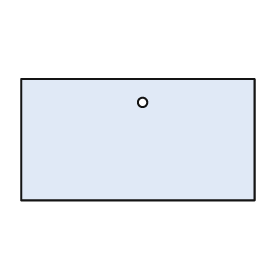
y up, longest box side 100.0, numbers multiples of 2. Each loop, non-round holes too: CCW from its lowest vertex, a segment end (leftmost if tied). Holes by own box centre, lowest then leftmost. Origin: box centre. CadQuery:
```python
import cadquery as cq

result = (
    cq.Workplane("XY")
    .moveTo(-50.0, -26.0)
    .lineTo(50.0, -26.0)
    .lineTo(50.0, 26.0)
    .lineTo(-50.0, 26.0)
    .close()
    .moveTo(2.0, 16.0)
    .circle(2.0)
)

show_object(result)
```